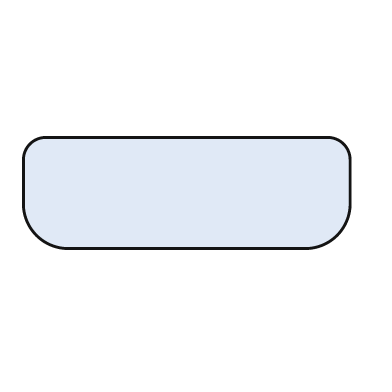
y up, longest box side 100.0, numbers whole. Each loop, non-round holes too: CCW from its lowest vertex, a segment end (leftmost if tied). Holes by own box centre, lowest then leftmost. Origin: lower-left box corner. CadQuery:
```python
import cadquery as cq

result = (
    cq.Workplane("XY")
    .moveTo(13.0, 0.0)
    .lineTo(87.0, 0.0)
    .threePointArc((96.0, 4.0), (100.0, 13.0))
    .lineTo(100.0, 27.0)
    .threePointArc((98.0, 32.0), (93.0, 34.0))
    .lineTo(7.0, 34.0)
    .threePointArc((2.0, 32.0), (0.0, 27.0))
    .lineTo(0.0, 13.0)
    .threePointArc((4.0, 4.0), (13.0, 0.0))
    .close()
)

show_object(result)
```